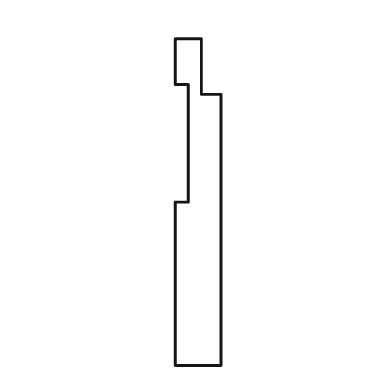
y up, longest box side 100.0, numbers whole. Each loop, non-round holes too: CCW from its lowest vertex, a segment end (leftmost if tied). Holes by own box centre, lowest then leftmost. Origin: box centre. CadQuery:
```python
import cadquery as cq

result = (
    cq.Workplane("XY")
    .moveTo(-7.0, -50.0)
    .lineTo(7.0, -50.0)
    .lineTo(7.0, 33.0)
    .lineTo(1.0, 33.0)
    .lineTo(1.0, 50.0)
    .lineTo(-7.0, 50.0)
    .lineTo(-7.0, 36.0)
    .lineTo(-3.0, 36.0)
    .lineTo(-3.0, 0.0)
    .lineTo(-7.0, 0.0)
    .close()
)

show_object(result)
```